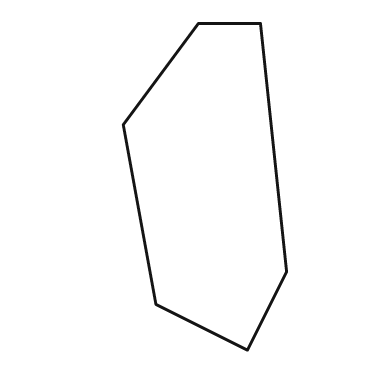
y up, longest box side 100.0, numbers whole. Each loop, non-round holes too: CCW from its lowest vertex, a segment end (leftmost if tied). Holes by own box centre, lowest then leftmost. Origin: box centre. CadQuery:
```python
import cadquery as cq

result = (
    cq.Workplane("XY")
    .moveTo(13.0, -50.0)
    .lineTo(25.0, -26.0)
    .lineTo(17.0, 50.0)
    .lineTo(-2.0, 50.0)
    .lineTo(-25.0, 19.0)
    .lineTo(-15.0, -36.0)
    .close()
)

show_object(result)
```